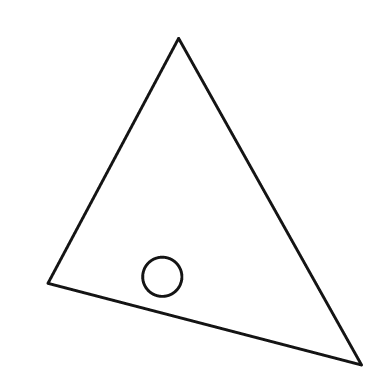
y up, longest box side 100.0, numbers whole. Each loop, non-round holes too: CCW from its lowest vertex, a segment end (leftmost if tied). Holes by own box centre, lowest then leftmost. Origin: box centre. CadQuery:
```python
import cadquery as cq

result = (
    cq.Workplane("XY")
    .moveTo(48.0, -50.0)
    .lineTo(-8.0, 50.0)
    .lineTo(-48.0, -25.0)
    .close()
    .moveTo(-13.0, -23.0)
    .circle(6.0)
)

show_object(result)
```